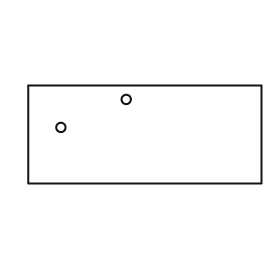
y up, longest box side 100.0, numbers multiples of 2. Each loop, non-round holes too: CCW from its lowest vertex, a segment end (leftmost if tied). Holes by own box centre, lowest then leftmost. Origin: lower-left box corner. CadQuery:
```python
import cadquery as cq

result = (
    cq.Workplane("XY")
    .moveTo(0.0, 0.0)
    .lineTo(100.0, 0.0)
    .lineTo(100.0, 42.0)
    .lineTo(0.0, 42.0)
    .close()
    .moveTo(14.0, 24.0)
    .circle(2.0)
    .moveTo(42.0, 36.0)
    .circle(2.0)
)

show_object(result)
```